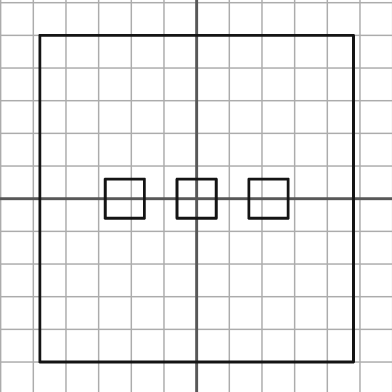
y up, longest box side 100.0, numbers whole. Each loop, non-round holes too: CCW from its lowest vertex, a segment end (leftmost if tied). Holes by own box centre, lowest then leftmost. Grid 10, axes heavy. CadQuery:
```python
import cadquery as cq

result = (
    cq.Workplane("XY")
    .moveTo(-48.0, -50.0)
    .lineTo(48.0, -50.0)
    .lineTo(48.0, 50.0)
    .lineTo(-48.0, 50.0)
    .close()
    .moveTo(-28.0, -6.0)
    .lineTo(-16.0, -6.0)
    .lineTo(-16.0, 6.0)
    .lineTo(-28.0, 6.0)
    .close()
    .moveTo(-6.0, -6.0)
    .lineTo(6.0, -6.0)
    .lineTo(6.0, 6.0)
    .lineTo(-6.0, 6.0)
    .close()
    .moveTo(16.0, -6.0)
    .lineTo(28.0, -6.0)
    .lineTo(28.0, 6.0)
    .lineTo(16.0, 6.0)
    .close()
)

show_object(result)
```